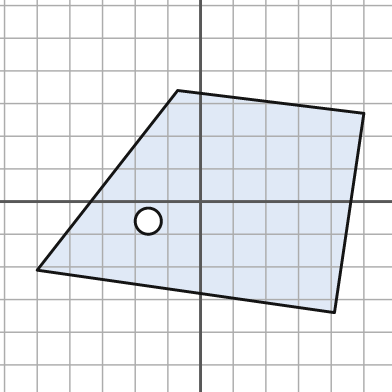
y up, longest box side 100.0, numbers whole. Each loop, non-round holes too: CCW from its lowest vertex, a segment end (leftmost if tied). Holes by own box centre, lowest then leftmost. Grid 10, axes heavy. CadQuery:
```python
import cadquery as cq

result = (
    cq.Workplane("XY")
    .moveTo(41.0, -34.0)
    .lineTo(50.0, 27.0)
    .lineTo(-7.0, 34.0)
    .lineTo(-50.0, -21.0)
    .close()
    .moveTo(-16.0, -6.0)
    .circle(4.0)
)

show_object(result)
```